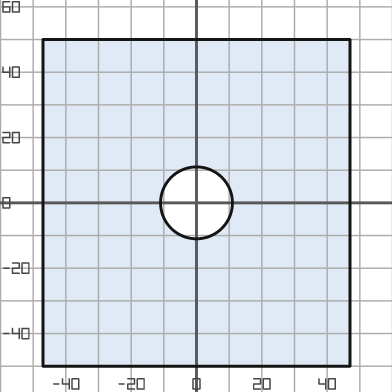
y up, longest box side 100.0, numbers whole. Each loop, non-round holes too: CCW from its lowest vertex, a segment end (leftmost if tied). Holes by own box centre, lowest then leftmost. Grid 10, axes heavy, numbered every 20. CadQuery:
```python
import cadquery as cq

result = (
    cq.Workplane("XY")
    .moveTo(-47.0, -50.0)
    .lineTo(47.0, -50.0)
    .lineTo(47.0, 50.0)
    .lineTo(-47.0, 50.0)
    .close()
    .moveTo(0.0, 0.0)
    .circle(11.0)
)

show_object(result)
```